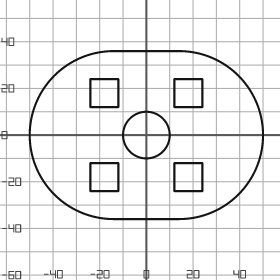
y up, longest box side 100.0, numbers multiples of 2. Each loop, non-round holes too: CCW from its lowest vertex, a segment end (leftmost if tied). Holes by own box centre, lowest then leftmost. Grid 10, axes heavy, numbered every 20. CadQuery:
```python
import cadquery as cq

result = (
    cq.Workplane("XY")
    .moveTo(-14.0, -36.0)
    .lineTo(14.0, -36.0)
    .threePointArc((50.0, 0.0), (14.0, 36.0))
    .lineTo(-14.0, 36.0)
    .threePointArc((-50.0, 0.0), (-14.0, -36.0))
    .close()
    .moveTo(-24.0, -24.0)
    .lineTo(-12.0, -24.0)
    .lineTo(-12.0, -12.0)
    .lineTo(-24.0, -12.0)
    .close()
    .moveTo(12.0, -24.0)
    .lineTo(24.0, -24.0)
    .lineTo(24.0, -12.0)
    .lineTo(12.0, -12.0)
    .close()
    .moveTo(0.0, 0.0)
    .circle(10.0)
    .moveTo(-24.0, 12.0)
    .lineTo(-12.0, 12.0)
    .lineTo(-12.0, 24.0)
    .lineTo(-24.0, 24.0)
    .close()
    .moveTo(12.0, 12.0)
    .lineTo(24.0, 12.0)
    .lineTo(24.0, 24.0)
    .lineTo(12.0, 24.0)
    .close()
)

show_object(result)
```